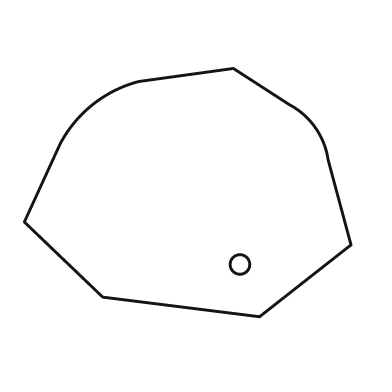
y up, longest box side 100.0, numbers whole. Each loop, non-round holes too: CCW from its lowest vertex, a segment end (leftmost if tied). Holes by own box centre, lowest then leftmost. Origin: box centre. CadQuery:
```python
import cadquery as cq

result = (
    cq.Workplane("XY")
    .moveTo(22.0, -38.0)
    .lineTo(50.0, -16.0)
    .lineTo(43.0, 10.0)
    .threePointArc((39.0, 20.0), (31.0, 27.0))
    .lineTo(14.0, 38.0)
    .lineTo(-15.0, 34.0)
    .threePointArc((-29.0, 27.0), (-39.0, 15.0))
    .lineTo(-50.0, -9.0)
    .lineTo(-26.0, -32.0)
    .close()
    .moveTo(16.0, -22.0)
    .circle(3.0)
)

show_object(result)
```